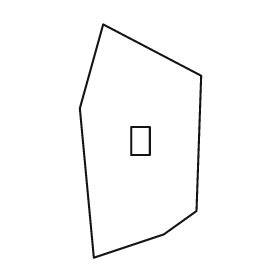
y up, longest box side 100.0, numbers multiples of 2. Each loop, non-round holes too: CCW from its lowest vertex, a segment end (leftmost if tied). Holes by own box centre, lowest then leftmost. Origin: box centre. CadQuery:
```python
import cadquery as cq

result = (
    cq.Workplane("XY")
    .moveTo(-20.0, -50.0)
    .lineTo(10.0, -40.0)
    .lineTo(24.0, -30.0)
    .lineTo(26.0, 28.0)
    .lineTo(-16.0, 50.0)
    .lineTo(-26.0, 14.0)
    .close()
    .moveTo(-4.0, -6.0)
    .lineTo(4.0, -6.0)
    .lineTo(4.0, 6.0)
    .lineTo(-4.0, 6.0)
    .close()
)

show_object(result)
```